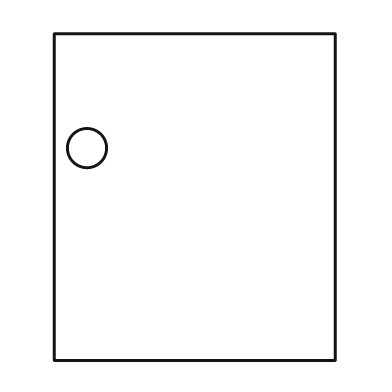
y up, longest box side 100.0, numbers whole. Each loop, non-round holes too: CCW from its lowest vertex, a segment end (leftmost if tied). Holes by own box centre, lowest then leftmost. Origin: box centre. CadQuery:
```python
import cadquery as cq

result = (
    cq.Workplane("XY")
    .moveTo(-43.0, -50.0)
    .lineTo(43.0, -50.0)
    .lineTo(43.0, 50.0)
    .lineTo(-43.0, 50.0)
    .close()
    .moveTo(-33.0, 15.0)
    .circle(6.0)
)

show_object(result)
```